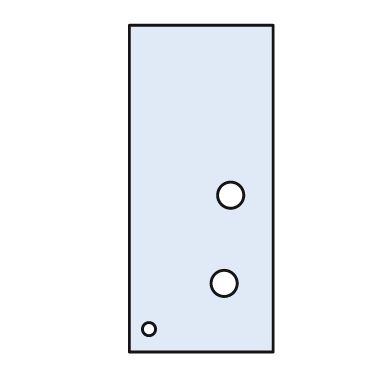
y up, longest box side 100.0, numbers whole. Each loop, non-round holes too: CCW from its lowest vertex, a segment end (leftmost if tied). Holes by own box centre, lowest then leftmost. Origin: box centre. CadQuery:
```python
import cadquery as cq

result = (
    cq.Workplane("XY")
    .moveTo(-22.0, -50.0)
    .lineTo(22.0, -50.0)
    .lineTo(22.0, 50.0)
    .lineTo(-22.0, 50.0)
    .close()
    .moveTo(-16.0, -43.0)
    .circle(2.0)
    .moveTo(7.0, -29.0)
    .circle(4.0)
    .moveTo(9.0, -2.0)
    .circle(4.0)
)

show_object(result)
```